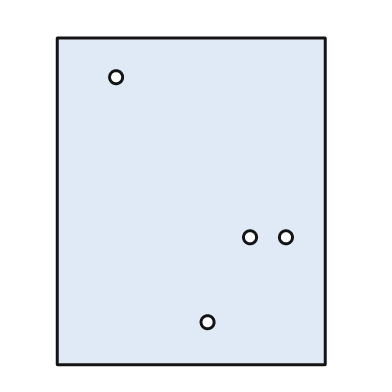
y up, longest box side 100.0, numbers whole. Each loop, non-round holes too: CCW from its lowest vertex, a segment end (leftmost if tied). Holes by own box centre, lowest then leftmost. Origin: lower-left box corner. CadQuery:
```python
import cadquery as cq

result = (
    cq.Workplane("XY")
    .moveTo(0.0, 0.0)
    .lineTo(82.0, 0.0)
    .lineTo(82.0, 100.0)
    .lineTo(0.0, 100.0)
    .close()
    .moveTo(46.0, 13.0)
    .circle(2.0)
    .moveTo(59.0, 39.0)
    .circle(2.0)
    .moveTo(70.0, 39.0)
    .circle(2.0)
    .moveTo(18.0, 88.0)
    .circle(2.0)
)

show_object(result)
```